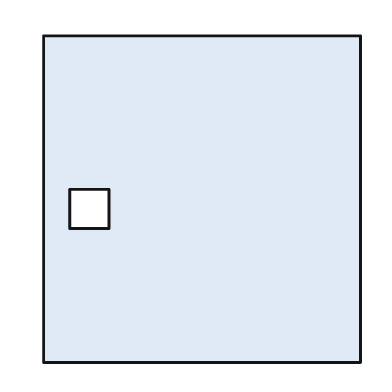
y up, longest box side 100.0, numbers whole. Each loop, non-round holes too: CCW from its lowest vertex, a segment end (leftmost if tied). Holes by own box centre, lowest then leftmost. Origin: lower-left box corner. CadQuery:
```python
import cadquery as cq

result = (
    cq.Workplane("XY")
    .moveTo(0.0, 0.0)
    .lineTo(97.0, 0.0)
    .lineTo(97.0, 100.0)
    .lineTo(0.0, 100.0)
    .close()
    .moveTo(8.0, 41.0)
    .lineTo(20.0, 41.0)
    .lineTo(20.0, 53.0)
    .lineTo(8.0, 53.0)
    .close()
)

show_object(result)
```